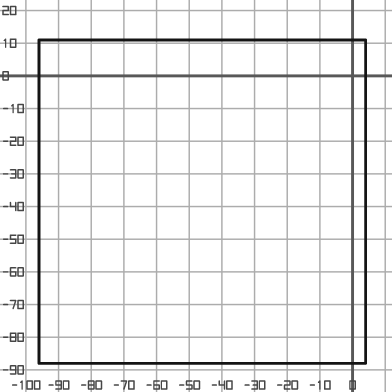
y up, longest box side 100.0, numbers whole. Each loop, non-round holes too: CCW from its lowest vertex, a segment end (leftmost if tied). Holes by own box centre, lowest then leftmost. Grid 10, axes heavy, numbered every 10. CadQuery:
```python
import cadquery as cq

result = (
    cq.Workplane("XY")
    .moveTo(-96.0, -88.0)
    .lineTo(4.0, -88.0)
    .lineTo(4.0, 11.0)
    .lineTo(-96.0, 11.0)
    .close()
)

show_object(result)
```